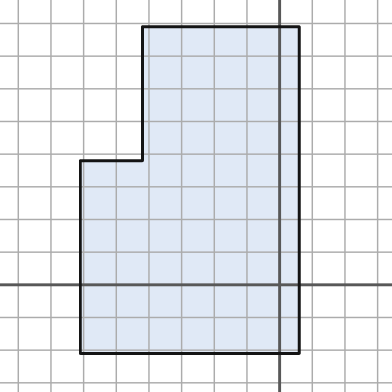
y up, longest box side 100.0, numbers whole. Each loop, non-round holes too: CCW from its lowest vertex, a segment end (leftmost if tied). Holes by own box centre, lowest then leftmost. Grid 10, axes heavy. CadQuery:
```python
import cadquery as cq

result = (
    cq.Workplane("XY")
    .moveTo(-61.0, -21.0)
    .lineTo(6.0, -21.0)
    .lineTo(6.0, 79.0)
    .lineTo(-42.0, 79.0)
    .lineTo(-42.0, 38.0)
    .lineTo(-61.0, 38.0)
    .close()
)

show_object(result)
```